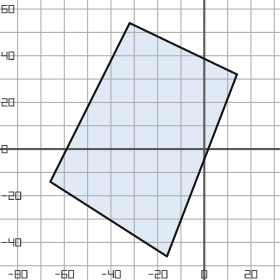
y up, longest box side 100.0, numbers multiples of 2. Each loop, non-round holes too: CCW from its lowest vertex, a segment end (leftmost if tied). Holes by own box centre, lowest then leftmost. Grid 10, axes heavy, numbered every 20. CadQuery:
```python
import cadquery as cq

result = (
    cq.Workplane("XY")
    .moveTo(-16.0, -46.0)
    .lineTo(14.0, 32.0)
    .lineTo(-32.0, 54.0)
    .lineTo(-66.0, -14.0)
    .close()
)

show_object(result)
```